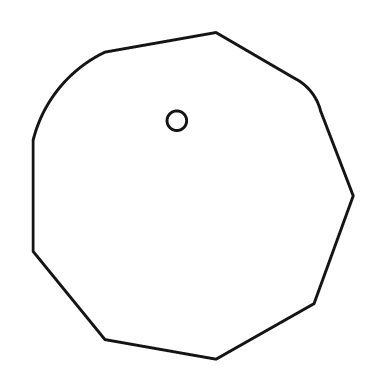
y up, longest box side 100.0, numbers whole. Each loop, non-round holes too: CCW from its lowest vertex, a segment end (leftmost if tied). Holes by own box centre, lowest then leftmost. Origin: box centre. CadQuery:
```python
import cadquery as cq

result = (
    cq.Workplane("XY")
    .moveTo(7.0, -50.0)
    .lineTo(37.0, -33.0)
    .lineTo(49.0, 0.0)
    .lineTo(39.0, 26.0)
    .threePointArc((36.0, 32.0), (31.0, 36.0))
    .lineTo(7.0, 50.0)
    .lineTo(-27.0, 44.0)
    .threePointArc((-41.0, 33.0), (-49.0, 17.0))
    .lineTo(-49.0, -17.0)
    .lineTo(-27.0, -44.0)
    .close()
    .moveTo(-5.0, 23.0)
    .circle(3.0)
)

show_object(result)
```